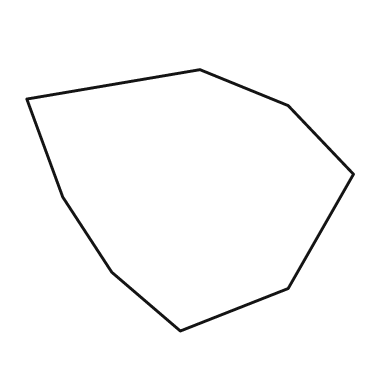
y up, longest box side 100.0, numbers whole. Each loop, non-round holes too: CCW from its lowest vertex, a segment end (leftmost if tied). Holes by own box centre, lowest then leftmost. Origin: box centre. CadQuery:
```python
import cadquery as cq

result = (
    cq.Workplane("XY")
    .moveTo(-3.0, -40.0)
    .lineTo(30.0, -27.0)
    .lineTo(50.0, 8.0)
    .lineTo(30.0, 29.0)
    .lineTo(3.0, 40.0)
    .lineTo(-50.0, 31.0)
    .lineTo(-39.0, 1.0)
    .lineTo(-24.0, -22.0)
    .close()
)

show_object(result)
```